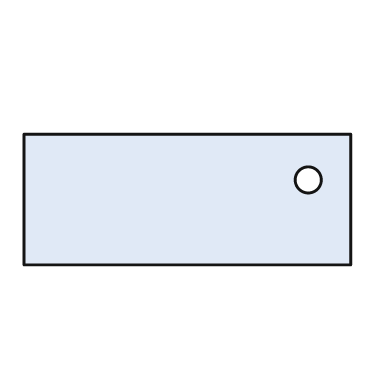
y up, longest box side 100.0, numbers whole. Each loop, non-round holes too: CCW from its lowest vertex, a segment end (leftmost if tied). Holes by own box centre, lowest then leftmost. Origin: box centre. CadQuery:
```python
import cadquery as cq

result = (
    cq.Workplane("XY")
    .moveTo(-50.0, -20.0)
    .lineTo(50.0, -20.0)
    .lineTo(50.0, 20.0)
    .lineTo(-50.0, 20.0)
    .close()
    .moveTo(37.0, 6.0)
    .circle(4.0)
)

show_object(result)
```